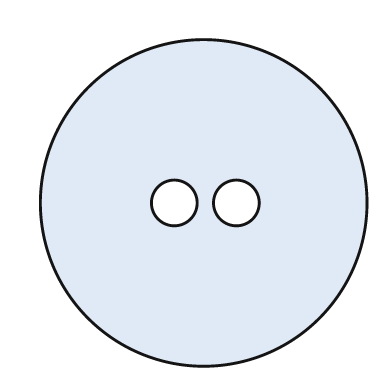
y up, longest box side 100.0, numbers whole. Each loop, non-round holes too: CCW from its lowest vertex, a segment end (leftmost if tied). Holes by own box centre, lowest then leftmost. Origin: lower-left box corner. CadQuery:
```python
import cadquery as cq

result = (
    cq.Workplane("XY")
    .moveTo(50.0, 50.0)
    .circle(50.0)
    .moveTo(41.0, 50.0)
    .circle(7.0)
    .moveTo(60.0, 50.0)
    .circle(7.0)
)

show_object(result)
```